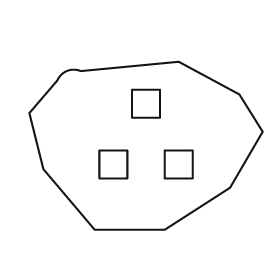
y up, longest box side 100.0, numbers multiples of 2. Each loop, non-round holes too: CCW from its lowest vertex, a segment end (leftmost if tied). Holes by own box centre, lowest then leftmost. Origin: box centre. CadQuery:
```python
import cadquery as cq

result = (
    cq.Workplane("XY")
    .moveTo(-22.0, -36.0)
    .lineTo(8.0, -36.0)
    .lineTo(36.0, -18.0)
    .lineTo(50.0, 6.0)
    .lineTo(40.0, 22.0)
    .lineTo(14.0, 36.0)
    .lineTo(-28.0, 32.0)
    .threePointArc((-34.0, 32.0), (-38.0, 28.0))
    .lineTo(-50.0, 14.0)
    .lineTo(-44.0, -10.0)
    .close()
    .moveTo(-20.0, -14.0)
    .lineTo(-8.0, -14.0)
    .lineTo(-8.0, -2.0)
    .lineTo(-20.0, -2.0)
    .close()
    .moveTo(8.0, -14.0)
    .lineTo(20.0, -14.0)
    .lineTo(20.0, -2.0)
    .lineTo(8.0, -2.0)
    .close()
    .moveTo(-6.0, 12.0)
    .lineTo(6.0, 12.0)
    .lineTo(6.0, 24.0)
    .lineTo(-6.0, 24.0)
    .close()
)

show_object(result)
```